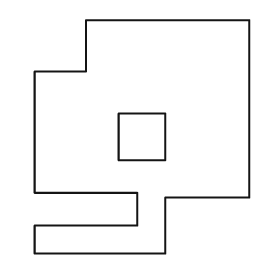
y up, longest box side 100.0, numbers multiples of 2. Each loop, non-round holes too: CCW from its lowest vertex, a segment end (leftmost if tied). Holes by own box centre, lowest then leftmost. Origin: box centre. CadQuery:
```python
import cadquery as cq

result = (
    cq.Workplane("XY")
    .moveTo(-46.0, -50.0)
    .lineTo(10.0, -50.0)
    .lineTo(10.0, -26.0)
    .lineTo(46.0, -26.0)
    .lineTo(46.0, 50.0)
    .lineTo(-24.0, 50.0)
    .lineTo(-24.0, 28.0)
    .lineTo(-46.0, 28.0)
    .lineTo(-46.0, -24.0)
    .lineTo(-2.0, -24.0)
    .lineTo(-2.0, -38.0)
    .lineTo(-46.0, -38.0)
    .close()
    .moveTo(-10.0, -10.0)
    .lineTo(10.0, -10.0)
    .lineTo(10.0, 10.0)
    .lineTo(-10.0, 10.0)
    .close()
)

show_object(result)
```